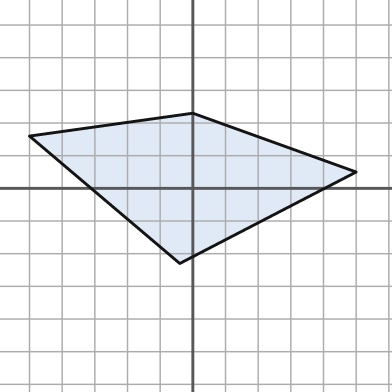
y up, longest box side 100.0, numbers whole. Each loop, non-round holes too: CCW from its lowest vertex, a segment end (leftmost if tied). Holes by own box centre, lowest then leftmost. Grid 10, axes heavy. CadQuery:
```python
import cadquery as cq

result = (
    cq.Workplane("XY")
    .moveTo(-4.0, -23.0)
    .lineTo(50.0, 5.0)
    .lineTo(0.0, 23.0)
    .lineTo(-50.0, 16.0)
    .close()
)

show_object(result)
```